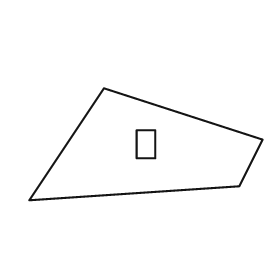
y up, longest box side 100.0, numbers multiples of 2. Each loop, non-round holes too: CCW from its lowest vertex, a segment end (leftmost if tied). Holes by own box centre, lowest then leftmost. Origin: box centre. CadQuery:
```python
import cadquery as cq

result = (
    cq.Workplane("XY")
    .moveTo(-50.0, -24.0)
    .lineTo(40.0, -18.0)
    .lineTo(50.0, 2.0)
    .lineTo(-18.0, 24.0)
    .close()
    .moveTo(-4.0, -6.0)
    .lineTo(4.0, -6.0)
    .lineTo(4.0, 6.0)
    .lineTo(-4.0, 6.0)
    .close()
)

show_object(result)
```